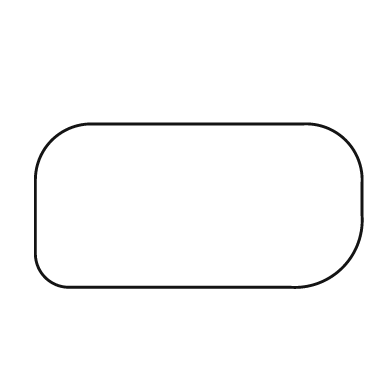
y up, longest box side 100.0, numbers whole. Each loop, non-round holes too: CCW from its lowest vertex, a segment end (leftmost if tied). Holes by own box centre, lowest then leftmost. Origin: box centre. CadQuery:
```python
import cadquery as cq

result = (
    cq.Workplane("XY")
    .moveTo(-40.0, -25.0)
    .lineTo(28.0, -25.0)
    .threePointArc((44.0, -19.0), (50.0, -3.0))
    .lineTo(50.0, 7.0)
    .threePointArc((45.0, 20.0), (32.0, 25.0))
    .lineTo(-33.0, 25.0)
    .threePointArc((-45.0, 20.0), (-50.0, 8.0))
    .lineTo(-50.0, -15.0)
    .threePointArc((-47.0, -22.0), (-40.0, -25.0))
    .close()
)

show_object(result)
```